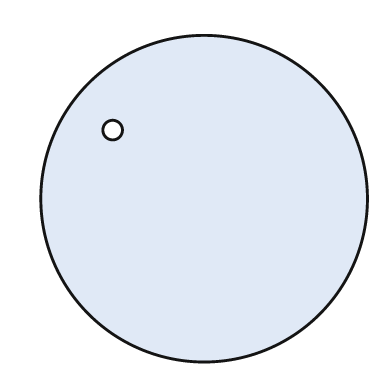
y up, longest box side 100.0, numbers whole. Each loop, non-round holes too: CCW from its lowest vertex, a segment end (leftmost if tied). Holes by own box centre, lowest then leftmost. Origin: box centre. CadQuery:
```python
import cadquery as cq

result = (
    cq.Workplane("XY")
    .moveTo(0.0, 0.0)
    .circle(50.0)
    .moveTo(-28.0, 21.0)
    .circle(3.0)
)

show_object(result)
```